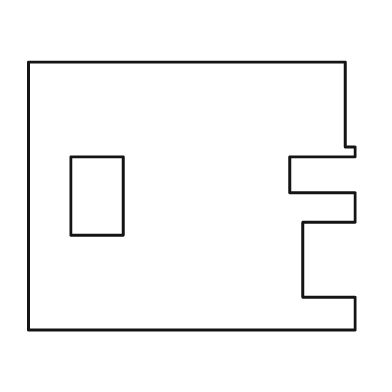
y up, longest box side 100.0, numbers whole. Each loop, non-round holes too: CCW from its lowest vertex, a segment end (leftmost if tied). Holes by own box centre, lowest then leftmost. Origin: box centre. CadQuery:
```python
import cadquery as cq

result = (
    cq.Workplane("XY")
    .moveTo(-50.0, -41.0)
    .lineTo(50.0, -41.0)
    .lineTo(50.0, -31.0)
    .lineTo(34.0, -31.0)
    .lineTo(34.0, -8.0)
    .lineTo(50.0, -8.0)
    .lineTo(50.0, 1.0)
    .lineTo(30.0, 1.0)
    .lineTo(30.0, 12.0)
    .lineTo(50.0, 12.0)
    .lineTo(50.0, 15.0)
    .lineTo(47.0, 15.0)
    .lineTo(47.0, 41.0)
    .lineTo(-50.0, 41.0)
    .close()
    .moveTo(-37.0, -12.0)
    .lineTo(-21.0, -12.0)
    .lineTo(-21.0, 12.0)
    .lineTo(-37.0, 12.0)
    .close()
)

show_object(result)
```